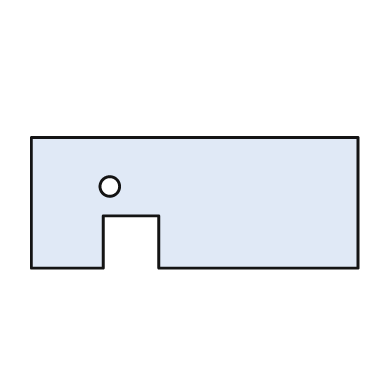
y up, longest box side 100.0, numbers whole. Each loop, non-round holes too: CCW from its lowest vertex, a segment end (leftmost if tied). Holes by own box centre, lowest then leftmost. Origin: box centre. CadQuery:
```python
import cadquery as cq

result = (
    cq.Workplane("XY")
    .moveTo(-50.0, -20.0)
    .lineTo(-28.0, -20.0)
    .lineTo(-28.0, -4.0)
    .lineTo(-11.0, -4.0)
    .lineTo(-11.0, -20.0)
    .lineTo(50.0, -20.0)
    .lineTo(50.0, 20.0)
    .lineTo(-50.0, 20.0)
    .close()
    .moveTo(-26.0, 5.0)
    .circle(3.0)
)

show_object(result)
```